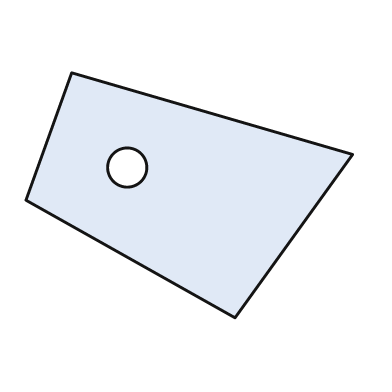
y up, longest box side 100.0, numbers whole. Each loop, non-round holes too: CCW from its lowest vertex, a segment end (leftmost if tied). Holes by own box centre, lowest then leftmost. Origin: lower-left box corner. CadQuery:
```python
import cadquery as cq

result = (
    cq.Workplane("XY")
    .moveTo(64.0, 0.0)
    .lineTo(100.0, 50.0)
    .lineTo(14.0, 75.0)
    .lineTo(0.0, 36.0)
    .close()
    .moveTo(31.0, 46.0)
    .circle(6.0)
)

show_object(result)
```